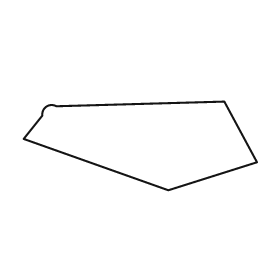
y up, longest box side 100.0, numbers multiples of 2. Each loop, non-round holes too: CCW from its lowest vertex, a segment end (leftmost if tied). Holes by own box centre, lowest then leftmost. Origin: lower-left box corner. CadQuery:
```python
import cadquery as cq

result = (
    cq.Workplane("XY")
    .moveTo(62.0, 0.0)
    .lineTo(100.0, 12.0)
    .lineTo(86.0, 38.0)
    .lineTo(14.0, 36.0)
    .threePointArc((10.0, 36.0), (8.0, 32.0))
    .lineTo(0.0, 22.0)
    .close()
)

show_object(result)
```